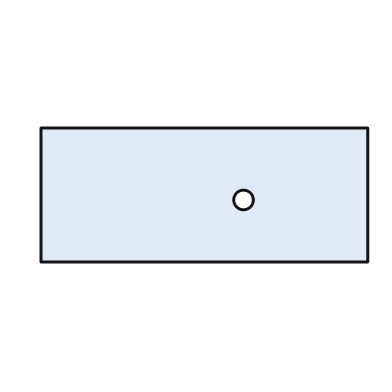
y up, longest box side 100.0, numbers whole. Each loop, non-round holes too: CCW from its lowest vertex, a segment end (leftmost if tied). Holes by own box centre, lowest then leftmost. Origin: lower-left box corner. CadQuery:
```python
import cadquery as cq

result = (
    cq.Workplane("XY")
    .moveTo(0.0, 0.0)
    .lineTo(100.0, 0.0)
    .lineTo(100.0, 41.0)
    .lineTo(0.0, 41.0)
    .close()
    .moveTo(62.0, 19.0)
    .circle(3.0)
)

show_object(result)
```